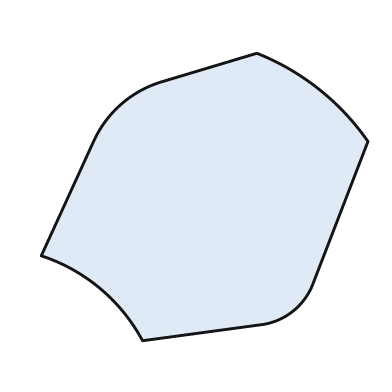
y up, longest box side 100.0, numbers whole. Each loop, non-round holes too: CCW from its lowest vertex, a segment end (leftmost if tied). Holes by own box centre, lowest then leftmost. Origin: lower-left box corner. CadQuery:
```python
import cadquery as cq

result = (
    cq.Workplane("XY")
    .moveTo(31.0, 0.0)
    .lineTo(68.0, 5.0)
    .threePointArc((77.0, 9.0), (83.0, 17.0))
    .lineTo(100.0, 61.0)
    .threePointArc((85.0, 77.0), (66.0, 88.0))
    .lineTo(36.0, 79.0)
    .threePointArc((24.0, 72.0), (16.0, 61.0))
    .lineTo(0.0, 26.0)
    .threePointArc((18.0, 16.0), (31.0, 0.0))
    .close()
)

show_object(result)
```